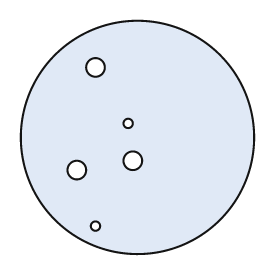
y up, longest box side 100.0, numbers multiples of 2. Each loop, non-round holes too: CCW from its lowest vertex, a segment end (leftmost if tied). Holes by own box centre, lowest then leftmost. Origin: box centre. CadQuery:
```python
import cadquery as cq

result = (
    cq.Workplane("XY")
    .moveTo(0.0, 0.0)
    .circle(50.0)
    .moveTo(-18.0, -38.0)
    .circle(2.0)
    .moveTo(-26.0, -14.0)
    .circle(4.0)
    .moveTo(-2.0, -10.0)
    .circle(4.0)
    .moveTo(-4.0, 6.0)
    .circle(2.0)
    .moveTo(-18.0, 30.0)
    .circle(4.0)
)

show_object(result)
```